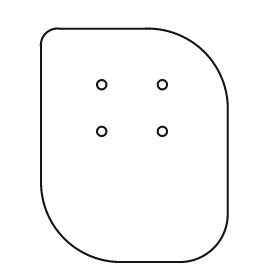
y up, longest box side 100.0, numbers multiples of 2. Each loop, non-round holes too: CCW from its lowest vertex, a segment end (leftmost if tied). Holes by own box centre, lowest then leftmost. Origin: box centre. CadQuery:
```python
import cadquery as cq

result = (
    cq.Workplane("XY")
    .moveTo(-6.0, -50.0)
    .lineTo(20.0, -50.0)
    .threePointArc((34.0, -44.0), (40.0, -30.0))
    .lineTo(40.0, 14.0)
    .threePointArc((30.0, 40.0), (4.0, 50.0))
    .lineTo(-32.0, 50.0)
    .threePointArc((-38.0, 48.0), (-40.0, 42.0))
    .lineTo(-40.0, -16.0)
    .threePointArc((-30.0, -40.0), (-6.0, -50.0))
    .close()
    .moveTo(-14.0, 6.0)
    .circle(2.0)
    .moveTo(12.0, 6.0)
    .circle(2.0)
    .moveTo(-14.0, 26.0)
    .circle(2.0)
    .moveTo(12.0, 26.0)
    .circle(2.0)
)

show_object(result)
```